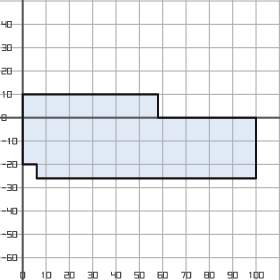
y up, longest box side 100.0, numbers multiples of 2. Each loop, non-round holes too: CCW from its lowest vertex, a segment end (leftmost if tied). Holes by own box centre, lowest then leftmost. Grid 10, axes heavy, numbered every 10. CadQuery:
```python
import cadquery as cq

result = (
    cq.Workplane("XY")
    .moveTo(6.0, -26.0)
    .lineTo(100.0, -26.0)
    .lineTo(100.0, 0.0)
    .lineTo(58.0, 0.0)
    .lineTo(58.0, 10.0)
    .lineTo(0.0, 10.0)
    .lineTo(0.0, -20.0)
    .lineTo(6.0, -20.0)
    .close()
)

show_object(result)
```